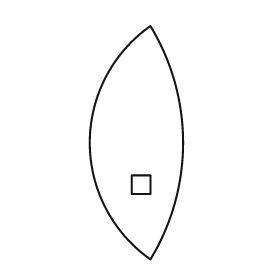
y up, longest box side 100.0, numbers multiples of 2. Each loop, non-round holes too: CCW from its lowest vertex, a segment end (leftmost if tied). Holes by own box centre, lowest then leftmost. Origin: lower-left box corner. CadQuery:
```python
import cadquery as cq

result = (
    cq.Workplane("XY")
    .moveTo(26.0, 0.0)
    .threePointArc((40.0, 50.0), (26.0, 100.0))
    .threePointArc((0.0, 50.0), (26.0, 0.0))
    .close()
    .moveTo(18.0, 28.0)
    .lineTo(26.0, 28.0)
    .lineTo(26.0, 36.0)
    .lineTo(18.0, 36.0)
    .close()
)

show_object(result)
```